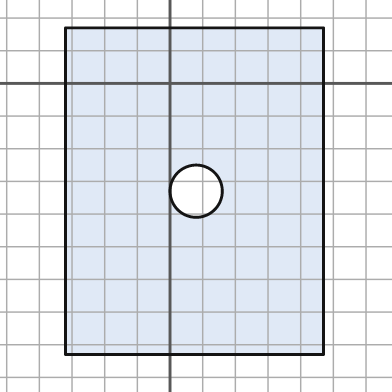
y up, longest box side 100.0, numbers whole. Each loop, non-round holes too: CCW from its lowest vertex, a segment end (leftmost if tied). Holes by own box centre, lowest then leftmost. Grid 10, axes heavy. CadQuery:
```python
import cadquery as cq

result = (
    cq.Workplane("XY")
    .moveTo(-32.0, -83.0)
    .lineTo(47.0, -83.0)
    .lineTo(47.0, 17.0)
    .lineTo(-32.0, 17.0)
    .close()
    .moveTo(8.0, -33.0)
    .circle(8.0)
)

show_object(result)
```